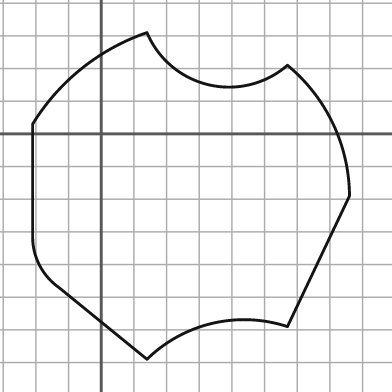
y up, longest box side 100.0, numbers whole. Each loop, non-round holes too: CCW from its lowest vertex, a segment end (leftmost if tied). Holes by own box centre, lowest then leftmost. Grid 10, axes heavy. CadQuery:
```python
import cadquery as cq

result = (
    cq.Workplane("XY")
    .moveTo(14.0, -69.0)
    .threePointArc((34.0, -58.0), (57.0, -59.0))
    .lineTo(76.0, -19.0)
    .threePointArc((71.0, 3.0), (57.0, 21.0))
    .threePointArc((33.0, 15.0), (14.0, 31.0))
    .threePointArc((-6.0, 20.0), (-21.0, 3.0))
    .lineTo(-21.0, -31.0)
    .threePointArc((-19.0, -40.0), (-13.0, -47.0))
    .close()
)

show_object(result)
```